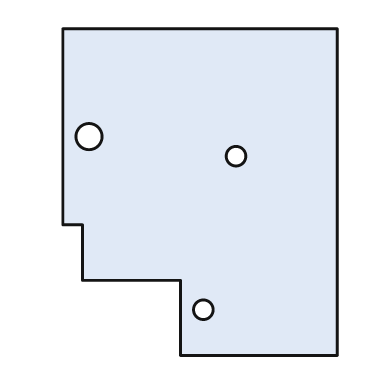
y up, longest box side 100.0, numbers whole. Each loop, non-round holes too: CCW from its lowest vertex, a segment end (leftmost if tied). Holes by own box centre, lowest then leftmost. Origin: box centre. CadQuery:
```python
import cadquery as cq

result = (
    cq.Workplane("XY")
    .moveTo(-6.0, -50.0)
    .lineTo(42.0, -50.0)
    .lineTo(42.0, 50.0)
    .lineTo(-42.0, 50.0)
    .lineTo(-42.0, -10.0)
    .lineTo(-36.0, -10.0)
    .lineTo(-36.0, -27.0)
    .lineTo(-6.0, -27.0)
    .close()
    .moveTo(1.0, -36.0)
    .circle(3.0)
    .moveTo(11.0, 11.0)
    .circle(3.0)
    .moveTo(-34.0, 17.0)
    .circle(4.0)
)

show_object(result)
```